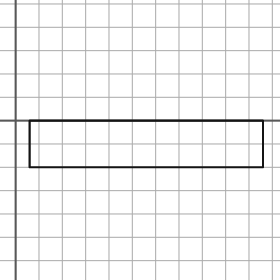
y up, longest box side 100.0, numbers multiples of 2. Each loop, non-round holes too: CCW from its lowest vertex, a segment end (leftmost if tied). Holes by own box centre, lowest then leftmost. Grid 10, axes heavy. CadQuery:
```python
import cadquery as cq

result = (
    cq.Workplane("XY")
    .moveTo(6.0, -20.0)
    .lineTo(106.0, -20.0)
    .lineTo(106.0, 0.0)
    .lineTo(6.0, 0.0)
    .close()
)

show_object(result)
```